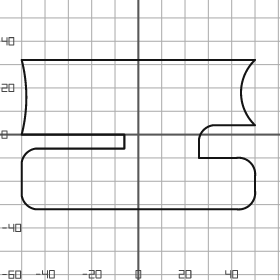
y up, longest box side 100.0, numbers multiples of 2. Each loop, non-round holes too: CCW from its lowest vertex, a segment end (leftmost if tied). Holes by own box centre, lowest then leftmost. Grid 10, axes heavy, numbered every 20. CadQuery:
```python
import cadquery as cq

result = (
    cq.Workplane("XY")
    .moveTo(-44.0, -32.0)
    .lineTo(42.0, -32.0)
    .threePointArc((48.0, -30.0), (50.0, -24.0))
    .lineTo(50.0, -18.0)
    .threePointArc((48.0, -12.0), (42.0, -10.0))
    .lineTo(26.0, -10.0)
    .lineTo(26.0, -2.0)
    .threePointArc((28.0, 2.0), (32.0, 4.0))
    .lineTo(50.0, 4.0)
    .threePointArc((44.0, 18.0), (50.0, 32.0))
    .lineTo(-50.0, 32.0)
    .threePointArc((-48.0, 16.0), (-50.0, 0.0))
    .lineTo(-6.0, 0.0)
    .lineTo(-6.0, -6.0)
    .lineTo(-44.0, -6.0)
    .threePointArc((-48.0, -8.0), (-50.0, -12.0))
    .lineTo(-50.0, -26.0)
    .threePointArc((-48.0, -30.0), (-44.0, -32.0))
    .close()
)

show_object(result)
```